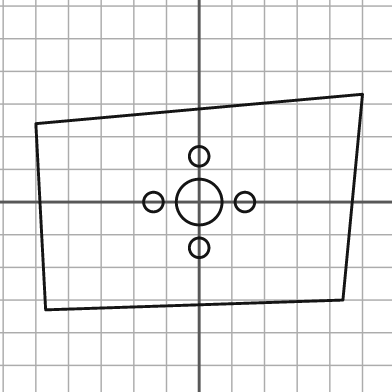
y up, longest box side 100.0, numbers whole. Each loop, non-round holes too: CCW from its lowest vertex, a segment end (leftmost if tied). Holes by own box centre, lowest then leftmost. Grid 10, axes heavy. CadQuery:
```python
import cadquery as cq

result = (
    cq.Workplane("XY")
    .moveTo(-47.0, -33.0)
    .lineTo(44.0, -30.0)
    .lineTo(50.0, 33.0)
    .lineTo(-50.0, 24.0)
    .close()
    .moveTo(0.0, -14.0)
    .circle(3.0)
    .moveTo(-14.0, 0.0)
    .circle(3.0)
    .moveTo(0.0, 0.0)
    .circle(7.0)
    .moveTo(14.0, 0.0)
    .circle(3.0)
    .moveTo(0.0, 14.0)
    .circle(3.0)
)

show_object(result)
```